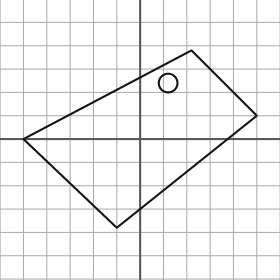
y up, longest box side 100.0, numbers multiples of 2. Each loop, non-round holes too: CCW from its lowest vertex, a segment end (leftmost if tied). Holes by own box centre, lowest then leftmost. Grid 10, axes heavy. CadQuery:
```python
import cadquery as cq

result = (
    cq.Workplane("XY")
    .moveTo(-10.0, -38.0)
    .lineTo(50.0, 10.0)
    .lineTo(22.0, 38.0)
    .lineTo(-50.0, 0.0)
    .close()
    .moveTo(12.0, 24.0)
    .circle(4.0)
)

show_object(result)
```